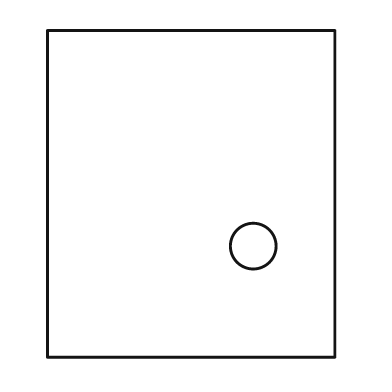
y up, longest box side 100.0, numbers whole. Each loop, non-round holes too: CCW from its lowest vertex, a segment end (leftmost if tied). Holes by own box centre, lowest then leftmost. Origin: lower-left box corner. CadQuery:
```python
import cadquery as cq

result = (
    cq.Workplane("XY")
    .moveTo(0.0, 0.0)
    .lineTo(88.0, 0.0)
    .lineTo(88.0, 100.0)
    .lineTo(0.0, 100.0)
    .close()
    .moveTo(63.0, 34.0)
    .circle(7.0)
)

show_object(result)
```